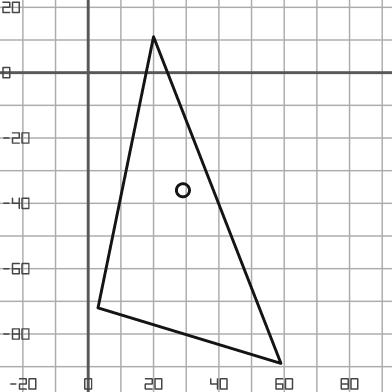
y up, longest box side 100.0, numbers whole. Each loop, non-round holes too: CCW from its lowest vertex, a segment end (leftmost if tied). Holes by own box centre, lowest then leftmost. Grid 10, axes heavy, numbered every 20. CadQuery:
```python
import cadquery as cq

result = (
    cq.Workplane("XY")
    .moveTo(59.0, -89.0)
    .lineTo(20.0, 11.0)
    .lineTo(3.0, -72.0)
    .close()
    .moveTo(29.0, -36.0)
    .circle(2.0)
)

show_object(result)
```